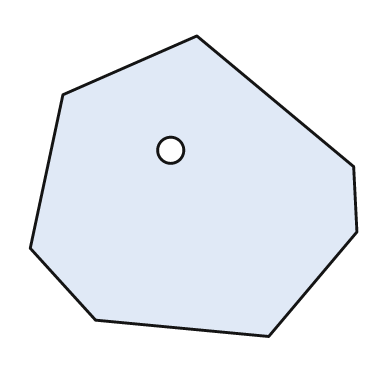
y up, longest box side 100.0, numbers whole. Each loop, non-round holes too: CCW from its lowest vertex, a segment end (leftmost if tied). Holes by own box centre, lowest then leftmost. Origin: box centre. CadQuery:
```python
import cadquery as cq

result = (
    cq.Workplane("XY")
    .moveTo(23.0, -46.0)
    .lineTo(50.0, -14.0)
    .lineTo(49.0, 6.0)
    .lineTo(1.0, 46.0)
    .lineTo(-40.0, 28.0)
    .lineTo(-50.0, -19.0)
    .lineTo(-30.0, -41.0)
    .close()
    .moveTo(-7.0, 11.0)
    .circle(4.0)
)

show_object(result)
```